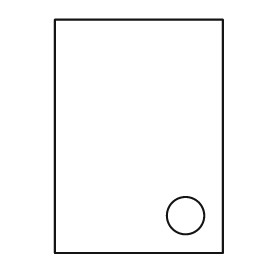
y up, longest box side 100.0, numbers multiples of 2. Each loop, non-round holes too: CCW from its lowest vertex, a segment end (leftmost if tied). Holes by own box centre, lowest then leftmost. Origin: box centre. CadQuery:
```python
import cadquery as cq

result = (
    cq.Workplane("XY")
    .moveTo(-36.0, -50.0)
    .lineTo(36.0, -50.0)
    .lineTo(36.0, 50.0)
    .lineTo(-36.0, 50.0)
    .close()
    .moveTo(20.0, -34.0)
    .circle(8.0)
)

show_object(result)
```